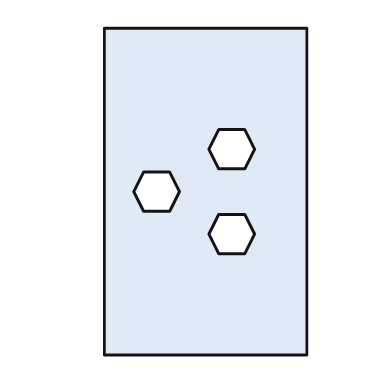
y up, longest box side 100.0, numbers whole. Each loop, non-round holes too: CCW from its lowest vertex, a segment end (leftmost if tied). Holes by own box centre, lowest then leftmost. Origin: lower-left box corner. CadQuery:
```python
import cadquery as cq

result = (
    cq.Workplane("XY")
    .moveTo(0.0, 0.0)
    .lineTo(62.0, 0.0)
    .lineTo(62.0, 100.0)
    .lineTo(0.0, 100.0)
    .close()
    .moveTo(35.0, 31.0)
    .lineTo(43.0, 31.0)
    .lineTo(46.0, 37.0)
    .lineTo(43.0, 43.0)
    .lineTo(35.0, 43.0)
    .lineTo(32.0, 37.0)
    .close()
    .moveTo(12.0, 44.0)
    .lineTo(20.0, 44.0)
    .lineTo(23.0, 50.0)
    .lineTo(20.0, 56.0)
    .lineTo(12.0, 56.0)
    .lineTo(9.0, 50.0)
    .close()
    .moveTo(35.0, 57.0)
    .lineTo(43.0, 57.0)
    .lineTo(46.0, 63.0)
    .lineTo(43.0, 69.0)
    .lineTo(35.0, 69.0)
    .lineTo(32.0, 63.0)
    .close()
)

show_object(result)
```